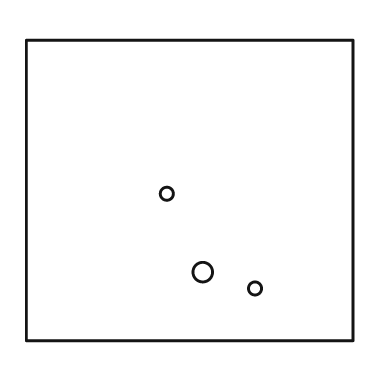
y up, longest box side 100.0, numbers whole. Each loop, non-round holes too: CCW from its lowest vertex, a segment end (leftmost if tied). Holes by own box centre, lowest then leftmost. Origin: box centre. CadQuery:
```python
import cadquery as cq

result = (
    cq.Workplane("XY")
    .moveTo(-50.0, -46.0)
    .lineTo(50.0, -46.0)
    .lineTo(50.0, 46.0)
    .lineTo(-50.0, 46.0)
    .close()
    .moveTo(20.0, -30.0)
    .circle(2.0)
    .moveTo(4.0, -25.0)
    .circle(3.0)
    .moveTo(-7.0, -1.0)
    .circle(2.0)
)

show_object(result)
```